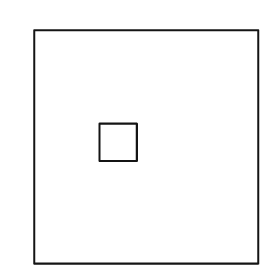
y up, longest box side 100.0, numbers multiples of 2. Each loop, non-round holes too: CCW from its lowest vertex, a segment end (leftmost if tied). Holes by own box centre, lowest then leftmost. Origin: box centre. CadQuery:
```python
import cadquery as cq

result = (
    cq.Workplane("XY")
    .moveTo(-48.0, -50.0)
    .lineTo(48.0, -50.0)
    .lineTo(48.0, 50.0)
    .lineTo(-48.0, 50.0)
    .close()
    .moveTo(-20.0, -6.0)
    .lineTo(-4.0, -6.0)
    .lineTo(-4.0, 10.0)
    .lineTo(-20.0, 10.0)
    .close()
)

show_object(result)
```